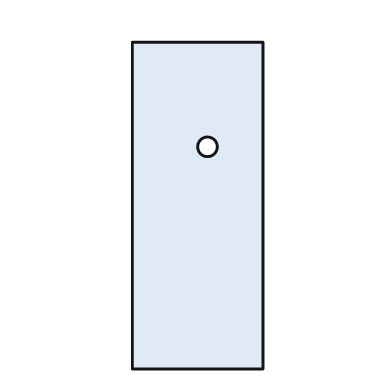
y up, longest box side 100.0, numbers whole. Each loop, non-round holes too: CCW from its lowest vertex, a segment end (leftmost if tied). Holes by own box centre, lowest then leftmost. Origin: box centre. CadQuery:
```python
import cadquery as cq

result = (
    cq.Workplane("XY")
    .moveTo(-20.0, -50.0)
    .lineTo(20.0, -50.0)
    .lineTo(20.0, 50.0)
    .lineTo(-20.0, 50.0)
    .close()
    .moveTo(3.0, 18.0)
    .circle(3.0)
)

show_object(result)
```